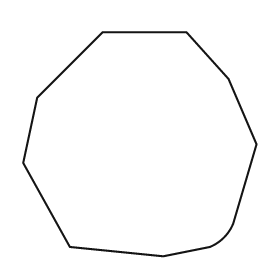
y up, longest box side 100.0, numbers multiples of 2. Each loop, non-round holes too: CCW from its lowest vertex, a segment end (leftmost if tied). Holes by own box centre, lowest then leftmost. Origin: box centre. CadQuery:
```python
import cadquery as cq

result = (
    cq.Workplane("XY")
    .moveTo(10.0, -48.0)
    .lineTo(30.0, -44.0)
    .threePointArc((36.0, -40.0), (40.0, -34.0))
    .lineTo(50.0, 0.0)
    .lineTo(38.0, 28.0)
    .lineTo(20.0, 48.0)
    .lineTo(-16.0, 48.0)
    .lineTo(-44.0, 20.0)
    .lineTo(-50.0, -8.0)
    .lineTo(-30.0, -44.0)
    .close()
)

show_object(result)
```